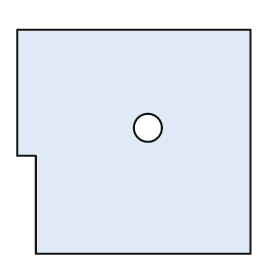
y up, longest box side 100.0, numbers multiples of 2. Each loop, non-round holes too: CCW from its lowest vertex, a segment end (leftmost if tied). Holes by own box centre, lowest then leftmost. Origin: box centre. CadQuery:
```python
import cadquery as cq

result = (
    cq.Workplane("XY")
    .moveTo(-42.0, -48.0)
    .lineTo(50.0, -48.0)
    .lineTo(50.0, 48.0)
    .lineTo(-50.0, 48.0)
    .lineTo(-50.0, -6.0)
    .lineTo(-42.0, -6.0)
    .close()
    .moveTo(6.0, 6.0)
    .circle(6.0)
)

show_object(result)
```